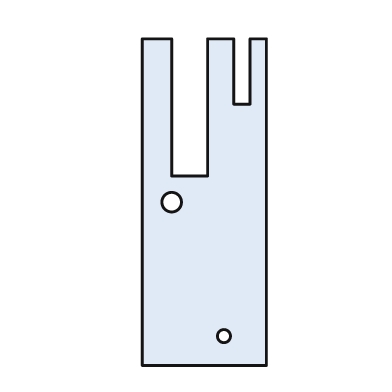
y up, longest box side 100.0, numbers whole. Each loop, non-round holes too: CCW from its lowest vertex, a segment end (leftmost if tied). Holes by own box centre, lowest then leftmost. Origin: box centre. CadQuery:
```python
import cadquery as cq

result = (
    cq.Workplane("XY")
    .moveTo(-19.0, -50.0)
    .lineTo(19.0, -50.0)
    .lineTo(19.0, 50.0)
    .lineTo(14.0, 50.0)
    .lineTo(14.0, 30.0)
    .lineTo(9.0, 30.0)
    .lineTo(9.0, 50.0)
    .lineTo(1.0, 50.0)
    .lineTo(1.0, 8.0)
    .lineTo(-10.0, 8.0)
    .lineTo(-10.0, 50.0)
    .lineTo(-19.0, 50.0)
    .close()
    .moveTo(6.0, -41.0)
    .circle(2.0)
    .moveTo(-10.0, 0.0)
    .circle(3.0)
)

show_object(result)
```